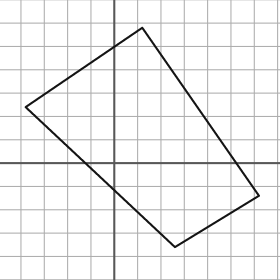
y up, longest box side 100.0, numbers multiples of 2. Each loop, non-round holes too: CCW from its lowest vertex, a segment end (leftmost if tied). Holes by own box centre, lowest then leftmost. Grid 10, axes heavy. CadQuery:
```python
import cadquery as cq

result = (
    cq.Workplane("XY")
    .moveTo(26.0, -36.0)
    .lineTo(62.0, -14.0)
    .lineTo(12.0, 58.0)
    .lineTo(-38.0, 24.0)
    .close()
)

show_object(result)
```